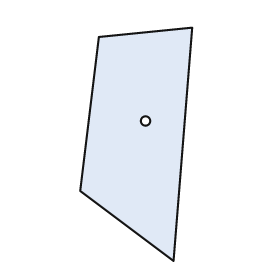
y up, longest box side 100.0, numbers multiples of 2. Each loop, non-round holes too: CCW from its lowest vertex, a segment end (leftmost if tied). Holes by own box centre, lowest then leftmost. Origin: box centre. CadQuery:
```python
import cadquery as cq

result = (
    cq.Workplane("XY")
    .moveTo(16.0, -50.0)
    .lineTo(24.0, 50.0)
    .lineTo(-16.0, 46.0)
    .lineTo(-24.0, -20.0)
    .close()
    .moveTo(4.0, 10.0)
    .circle(2.0)
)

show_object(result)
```